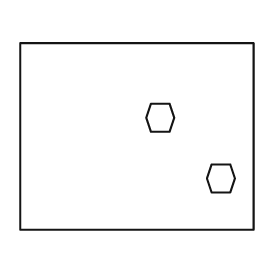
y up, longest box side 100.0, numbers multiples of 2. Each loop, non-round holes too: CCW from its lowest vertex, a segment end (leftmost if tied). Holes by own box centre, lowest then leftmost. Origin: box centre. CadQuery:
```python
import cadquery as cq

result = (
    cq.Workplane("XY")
    .moveTo(-50.0, -40.0)
    .lineTo(50.0, -40.0)
    .lineTo(50.0, 40.0)
    .lineTo(-50.0, 40.0)
    .close()
    .moveTo(32.0, -24.0)
    .lineTo(40.0, -24.0)
    .lineTo(42.0, -18.0)
    .lineTo(40.0, -12.0)
    .lineTo(32.0, -12.0)
    .lineTo(30.0, -18.0)
    .close()
    .moveTo(6.0, 2.0)
    .lineTo(14.0, 2.0)
    .lineTo(16.0, 8.0)
    .lineTo(14.0, 14.0)
    .lineTo(6.0, 14.0)
    .lineTo(4.0, 8.0)
    .close()
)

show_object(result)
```